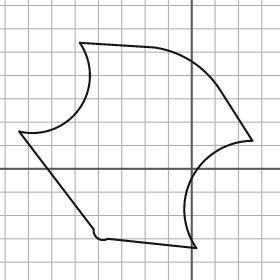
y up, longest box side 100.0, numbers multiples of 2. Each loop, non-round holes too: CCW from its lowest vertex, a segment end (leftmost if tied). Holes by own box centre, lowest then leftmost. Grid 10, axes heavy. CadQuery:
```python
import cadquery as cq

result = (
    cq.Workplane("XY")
    .moveTo(2.0, -34.0)
    .threePointArc((0.0, -4.0), (26.0, 12.0))
    .lineTo(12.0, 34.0)
    .threePointArc((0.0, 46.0), (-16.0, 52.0))
    .lineTo(-48.0, 54.0)
    .threePointArc((-48.0, 26.0), (-74.0, 16.0))
    .lineTo(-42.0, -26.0)
    .threePointArc((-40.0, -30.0), (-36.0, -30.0))
    .close()
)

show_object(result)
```